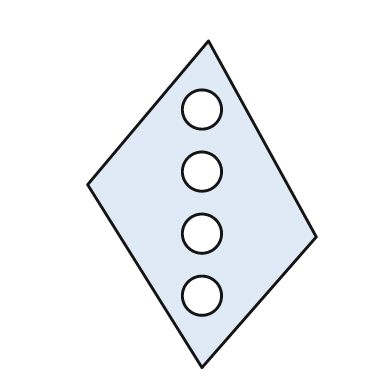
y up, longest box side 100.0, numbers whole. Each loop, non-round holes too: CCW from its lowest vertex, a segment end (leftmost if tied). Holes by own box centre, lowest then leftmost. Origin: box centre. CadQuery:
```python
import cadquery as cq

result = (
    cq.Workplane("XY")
    .moveTo(0.0, -50.0)
    .lineTo(35.0, -10.0)
    .lineTo(2.0, 50.0)
    .lineTo(-35.0, 6.0)
    .close()
    .moveTo(0.0, -28.0)
    .circle(6.0)
    .moveTo(0.0, -9.0)
    .circle(6.0)
    .moveTo(0.0, 10.0)
    .circle(6.0)
    .moveTo(0.0, 29.0)
    .circle(6.0)
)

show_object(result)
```